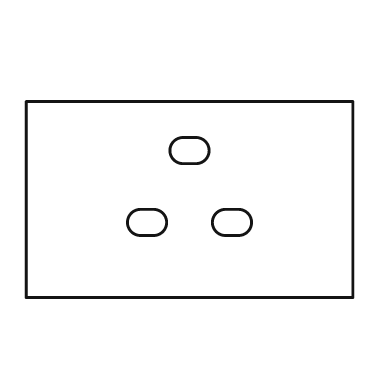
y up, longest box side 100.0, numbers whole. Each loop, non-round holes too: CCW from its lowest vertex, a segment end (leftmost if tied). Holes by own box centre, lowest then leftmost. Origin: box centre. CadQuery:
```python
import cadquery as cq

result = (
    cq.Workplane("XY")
    .moveTo(-50.0, -30.0)
    .lineTo(50.0, -30.0)
    .lineTo(50.0, 30.0)
    .lineTo(-50.0, 30.0)
    .close()
    .moveTo(-15.0, -11.0)
    .lineTo(-11.0, -11.0)
    .threePointArc((-7.0, -7.0), (-11.0, -3.0))
    .lineTo(-15.0, -3.0)
    .threePointArc((-19.0, -7.0), (-15.0, -11.0))
    .close()
    .moveTo(11.0, -11.0)
    .lineTo(15.0, -11.0)
    .threePointArc((19.0, -7.0), (15.0, -3.0))
    .lineTo(11.0, -3.0)
    .threePointArc((7.0, -7.0), (11.0, -11.0))
    .close()
    .moveTo(-2.0, 11.0)
    .lineTo(2.0, 11.0)
    .threePointArc((6.0, 15.0), (2.0, 19.0))
    .lineTo(-2.0, 19.0)
    .threePointArc((-6.0, 15.0), (-2.0, 11.0))
    .close()
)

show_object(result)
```